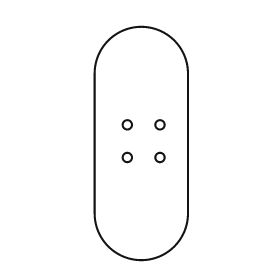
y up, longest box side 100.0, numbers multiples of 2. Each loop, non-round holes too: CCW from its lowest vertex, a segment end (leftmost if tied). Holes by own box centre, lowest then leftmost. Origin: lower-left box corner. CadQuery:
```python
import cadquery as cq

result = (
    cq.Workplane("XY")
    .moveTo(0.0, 20.0)
    .threePointArc((20.0, 0.0), (40.0, 20.0))
    .lineTo(40.0, 80.0)
    .threePointArc((20.0, 100.0), (0.0, 80.0))
    .close()
    .moveTo(14.0, 44.0)
    .circle(2.0)
    .moveTo(28.0, 44.0)
    .circle(2.0)
    .moveTo(14.0, 58.0)
    .circle(2.0)
    .moveTo(28.0, 58.0)
    .circle(2.0)
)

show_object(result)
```